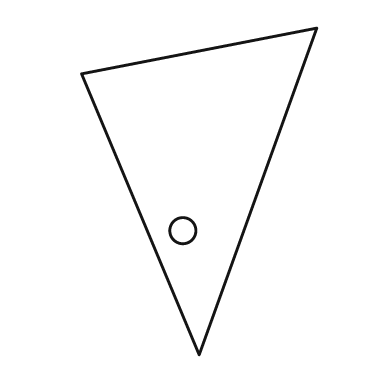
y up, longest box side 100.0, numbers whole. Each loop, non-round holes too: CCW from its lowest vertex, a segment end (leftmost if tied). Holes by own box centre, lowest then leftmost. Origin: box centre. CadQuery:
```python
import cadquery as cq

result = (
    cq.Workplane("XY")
    .moveTo(0.0, -50.0)
    .lineTo(36.0, 50.0)
    .lineTo(-36.0, 36.0)
    .close()
    .moveTo(-5.0, -12.0)
    .circle(4.0)
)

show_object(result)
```